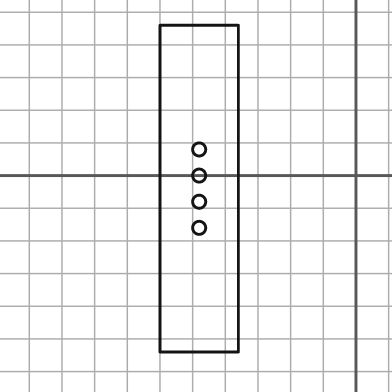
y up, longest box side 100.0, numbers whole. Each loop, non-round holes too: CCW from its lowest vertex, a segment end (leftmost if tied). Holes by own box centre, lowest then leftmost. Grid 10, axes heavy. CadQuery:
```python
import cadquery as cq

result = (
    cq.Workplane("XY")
    .moveTo(-60.0, -54.0)
    .lineTo(-36.0, -54.0)
    .lineTo(-36.0, 46.0)
    .lineTo(-60.0, 46.0)
    .close()
    .moveTo(-48.0, -16.0)
    .circle(2.0)
    .moveTo(-48.0, -8.0)
    .circle(2.0)
    .moveTo(-48.0, 0.0)
    .circle(2.0)
    .moveTo(-48.0, 8.0)
    .circle(2.0)
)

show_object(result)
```